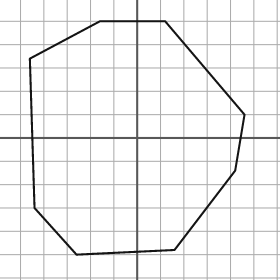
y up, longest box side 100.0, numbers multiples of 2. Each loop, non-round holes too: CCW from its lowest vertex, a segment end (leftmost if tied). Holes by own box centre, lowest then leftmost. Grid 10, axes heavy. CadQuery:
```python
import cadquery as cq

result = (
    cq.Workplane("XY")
    .moveTo(-26.0, -50.0)
    .lineTo(16.0, -48.0)
    .lineTo(42.0, -14.0)
    .lineTo(46.0, 10.0)
    .lineTo(12.0, 50.0)
    .lineTo(-16.0, 50.0)
    .lineTo(-46.0, 34.0)
    .lineTo(-44.0, -30.0)
    .close()
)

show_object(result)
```